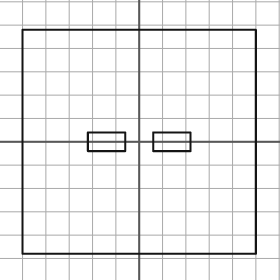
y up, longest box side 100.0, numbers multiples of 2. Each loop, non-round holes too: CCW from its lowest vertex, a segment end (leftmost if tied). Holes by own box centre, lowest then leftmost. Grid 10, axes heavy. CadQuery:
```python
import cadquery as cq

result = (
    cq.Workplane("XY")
    .moveTo(-50.0, -48.0)
    .lineTo(50.0, -48.0)
    .lineTo(50.0, 48.0)
    .lineTo(-50.0, 48.0)
    .close()
    .moveTo(-22.0, -4.0)
    .lineTo(-6.0, -4.0)
    .lineTo(-6.0, 4.0)
    .lineTo(-22.0, 4.0)
    .close()
    .moveTo(6.0, -4.0)
    .lineTo(22.0, -4.0)
    .lineTo(22.0, 4.0)
    .lineTo(6.0, 4.0)
    .close()
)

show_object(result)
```